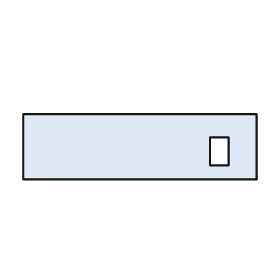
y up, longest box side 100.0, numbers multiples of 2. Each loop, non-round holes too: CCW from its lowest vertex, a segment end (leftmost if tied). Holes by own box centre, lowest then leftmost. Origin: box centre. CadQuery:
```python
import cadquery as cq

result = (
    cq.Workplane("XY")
    .moveTo(-50.0, -14.0)
    .lineTo(50.0, -14.0)
    .lineTo(50.0, 14.0)
    .lineTo(-50.0, 14.0)
    .close()
    .moveTo(30.0, -8.0)
    .lineTo(38.0, -8.0)
    .lineTo(38.0, 4.0)
    .lineTo(30.0, 4.0)
    .close()
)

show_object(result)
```